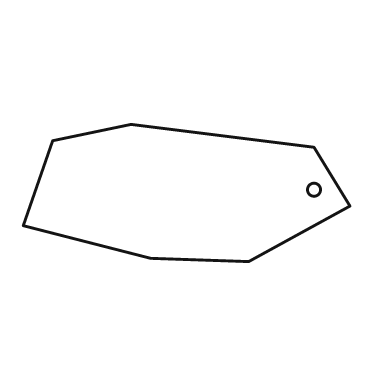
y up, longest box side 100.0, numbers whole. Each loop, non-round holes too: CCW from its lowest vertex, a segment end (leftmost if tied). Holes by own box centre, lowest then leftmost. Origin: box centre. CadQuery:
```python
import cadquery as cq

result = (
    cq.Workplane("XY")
    .moveTo(19.0, -21.0)
    .lineTo(50.0, -4.0)
    .lineTo(39.0, 14.0)
    .lineTo(-17.0, 21.0)
    .lineTo(-41.0, 16.0)
    .lineTo(-50.0, -10.0)
    .lineTo(-11.0, -20.0)
    .close()
    .moveTo(39.0, 1.0)
    .circle(2.0)
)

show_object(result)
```